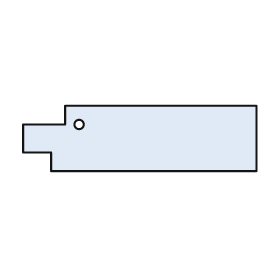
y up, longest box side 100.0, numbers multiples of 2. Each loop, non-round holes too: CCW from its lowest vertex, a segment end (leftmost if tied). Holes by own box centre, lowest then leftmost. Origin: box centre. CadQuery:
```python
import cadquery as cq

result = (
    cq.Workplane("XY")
    .moveTo(-38.0, -14.0)
    .lineTo(50.0, -14.0)
    .lineTo(50.0, 14.0)
    .lineTo(-32.0, 14.0)
    .lineTo(-32.0, 6.0)
    .lineTo(-50.0, 6.0)
    .lineTo(-50.0, -6.0)
    .lineTo(-38.0, -6.0)
    .close()
    .moveTo(-26.0, 6.0)
    .circle(2.0)
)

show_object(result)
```